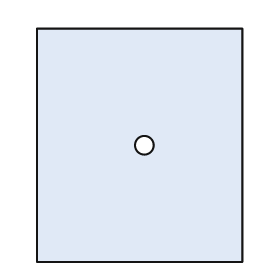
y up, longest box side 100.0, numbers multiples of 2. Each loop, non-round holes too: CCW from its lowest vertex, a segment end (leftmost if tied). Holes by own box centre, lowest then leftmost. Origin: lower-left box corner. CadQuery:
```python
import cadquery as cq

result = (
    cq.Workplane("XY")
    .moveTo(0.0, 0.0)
    .lineTo(88.0, 0.0)
    .lineTo(88.0, 100.0)
    .lineTo(0.0, 100.0)
    .close()
    .moveTo(46.0, 50.0)
    .circle(4.0)
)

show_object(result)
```